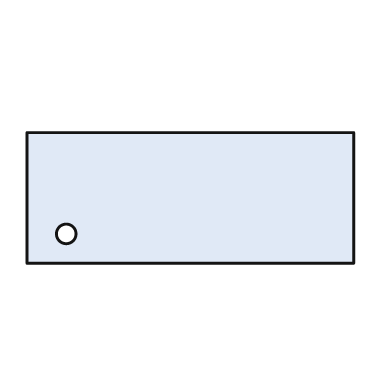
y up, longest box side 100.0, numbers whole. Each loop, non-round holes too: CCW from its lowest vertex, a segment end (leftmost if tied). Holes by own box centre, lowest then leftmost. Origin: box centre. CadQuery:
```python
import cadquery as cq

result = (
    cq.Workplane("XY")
    .moveTo(-50.0, -20.0)
    .lineTo(50.0, -20.0)
    .lineTo(50.0, 20.0)
    .lineTo(-50.0, 20.0)
    .close()
    .moveTo(-38.0, -11.0)
    .circle(3.0)
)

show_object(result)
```